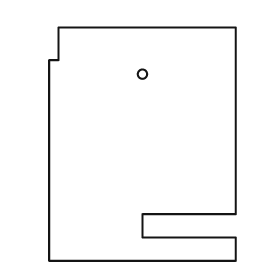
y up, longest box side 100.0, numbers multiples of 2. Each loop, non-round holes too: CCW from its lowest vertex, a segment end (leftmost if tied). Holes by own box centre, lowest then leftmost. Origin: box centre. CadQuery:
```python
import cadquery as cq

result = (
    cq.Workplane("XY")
    .moveTo(-40.0, -50.0)
    .lineTo(40.0, -50.0)
    .lineTo(40.0, -40.0)
    .lineTo(0.0, -40.0)
    .lineTo(0.0, -30.0)
    .lineTo(40.0, -30.0)
    .lineTo(40.0, 50.0)
    .lineTo(-36.0, 50.0)
    .lineTo(-36.0, 36.0)
    .lineTo(-40.0, 36.0)
    .close()
    .moveTo(0.0, 30.0)
    .circle(2.0)
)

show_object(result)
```